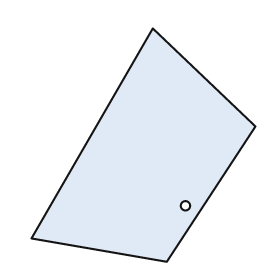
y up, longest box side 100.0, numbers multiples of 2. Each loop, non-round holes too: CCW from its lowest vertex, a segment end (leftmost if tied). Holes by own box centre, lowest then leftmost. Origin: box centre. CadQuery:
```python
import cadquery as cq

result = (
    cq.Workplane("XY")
    .moveTo(10.0, -50.0)
    .lineTo(48.0, 8.0)
    .lineTo(4.0, 50.0)
    .lineTo(-48.0, -40.0)
    .close()
    .moveTo(18.0, -26.0)
    .circle(2.0)
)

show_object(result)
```